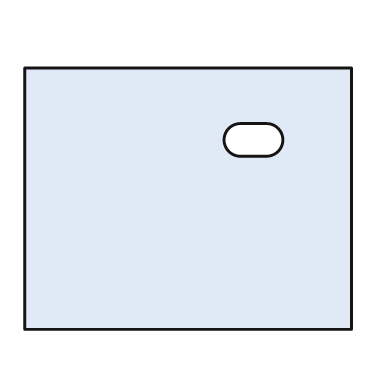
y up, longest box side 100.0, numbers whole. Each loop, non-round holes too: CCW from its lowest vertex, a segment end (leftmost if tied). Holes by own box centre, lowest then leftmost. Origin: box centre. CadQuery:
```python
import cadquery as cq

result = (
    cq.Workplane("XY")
    .moveTo(-50.0, -40.0)
    .lineTo(50.0, -40.0)
    .lineTo(50.0, 40.0)
    .lineTo(-50.0, 40.0)
    .close()
    .moveTo(16.0, 13.0)
    .lineTo(24.0, 13.0)
    .threePointArc((29.0, 18.0), (24.0, 23.0))
    .lineTo(16.0, 23.0)
    .threePointArc((11.0, 18.0), (16.0, 13.0))
    .close()
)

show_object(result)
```